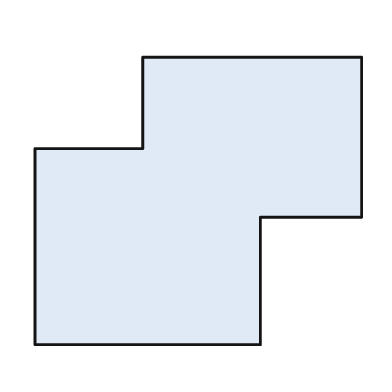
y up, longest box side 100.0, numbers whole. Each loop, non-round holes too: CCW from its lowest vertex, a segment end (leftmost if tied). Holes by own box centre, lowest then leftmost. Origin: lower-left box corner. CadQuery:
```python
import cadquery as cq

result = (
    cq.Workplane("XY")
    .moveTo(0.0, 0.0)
    .lineTo(69.0, 0.0)
    .lineTo(69.0, 39.0)
    .lineTo(100.0, 39.0)
    .lineTo(100.0, 88.0)
    .lineTo(33.0, 88.0)
    .lineTo(33.0, 60.0)
    .lineTo(0.0, 60.0)
    .close()
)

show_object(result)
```